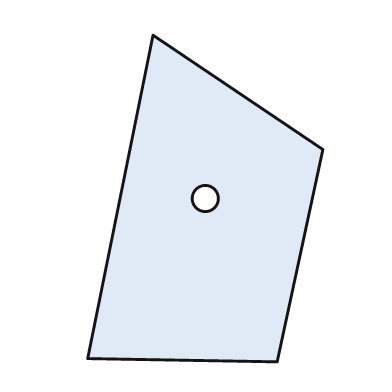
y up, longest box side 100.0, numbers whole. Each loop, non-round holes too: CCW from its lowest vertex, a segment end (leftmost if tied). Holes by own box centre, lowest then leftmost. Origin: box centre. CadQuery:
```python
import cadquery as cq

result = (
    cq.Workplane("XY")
    .moveTo(22.0, -50.0)
    .lineTo(36.0, 15.0)
    .lineTo(-16.0, 50.0)
    .lineTo(-36.0, -49.0)
    .close()
    .moveTo(0.0, 0.0)
    .circle(4.0)
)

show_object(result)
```